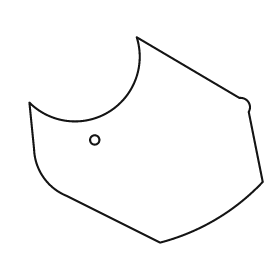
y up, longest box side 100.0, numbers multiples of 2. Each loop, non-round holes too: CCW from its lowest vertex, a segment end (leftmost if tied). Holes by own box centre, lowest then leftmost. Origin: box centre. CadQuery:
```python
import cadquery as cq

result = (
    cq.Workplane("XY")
    .moveTo(6.0, -44.0)
    .threePointArc((30.0, -34.0), (50.0, -18.0))
    .lineTo(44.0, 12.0)
    .threePointArc((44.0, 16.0), (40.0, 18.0))
    .lineTo(-4.0, 44.0)
    .threePointArc((-16.0, 12.0), (-50.0, 16.0))
    .lineTo(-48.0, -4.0)
    .threePointArc((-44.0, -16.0), (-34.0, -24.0))
    .close()
    .moveTo(-22.0, 0.0)
    .circle(2.0)
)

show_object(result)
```